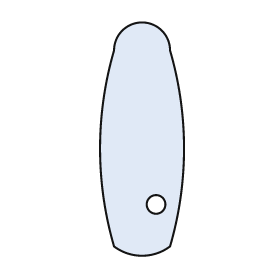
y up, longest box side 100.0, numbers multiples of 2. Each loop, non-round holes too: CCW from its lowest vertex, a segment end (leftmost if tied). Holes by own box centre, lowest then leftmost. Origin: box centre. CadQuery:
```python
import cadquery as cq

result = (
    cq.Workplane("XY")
    .moveTo(-12.0, -46.0)
    .threePointArc((0.0, -50.0), (12.0, -46.0))
    .threePointArc((18.0, -4.0), (12.0, 38.0))
    .threePointArc((0.0, 50.0), (-12.0, 38.0))
    .threePointArc((-18.0, -4.0), (-12.0, -46.0))
    .close()
    .moveTo(6.0, -28.0)
    .circle(4.0)
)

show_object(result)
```